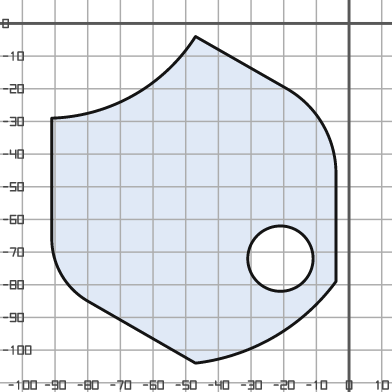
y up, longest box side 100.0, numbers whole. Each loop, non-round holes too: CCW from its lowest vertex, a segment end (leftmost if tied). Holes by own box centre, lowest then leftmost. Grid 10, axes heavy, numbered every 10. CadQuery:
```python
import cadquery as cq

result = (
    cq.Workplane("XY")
    .moveTo(-47.0, -104.0)
    .threePointArc((-23.0, -96.0), (-4.0, -79.0))
    .lineTo(-4.0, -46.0)
    .threePointArc((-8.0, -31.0), (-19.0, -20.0))
    .lineTo(-47.0, -4.0)
    .threePointArc((-66.0, -22.0), (-91.0, -29.0))
    .lineTo(-91.0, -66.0)
    .threePointArc((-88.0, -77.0), (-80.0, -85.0))
    .close()
    .moveTo(-21.0, -72.0)
    .circle(10.0)
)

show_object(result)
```